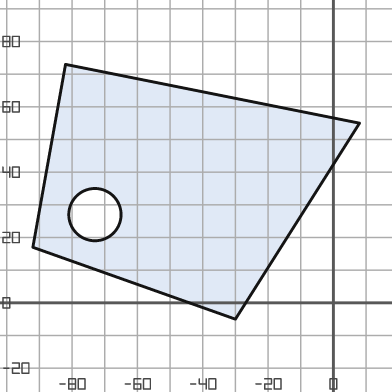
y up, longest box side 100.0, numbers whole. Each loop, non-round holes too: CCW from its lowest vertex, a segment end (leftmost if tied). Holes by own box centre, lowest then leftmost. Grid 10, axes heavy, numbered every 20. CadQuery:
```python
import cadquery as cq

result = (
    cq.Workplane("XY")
    .moveTo(-30.0, -5.0)
    .lineTo(8.0, 55.0)
    .lineTo(-82.0, 73.0)
    .lineTo(-92.0, 17.0)
    .close()
    .moveTo(-73.0, 27.0)
    .circle(8.0)
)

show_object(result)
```